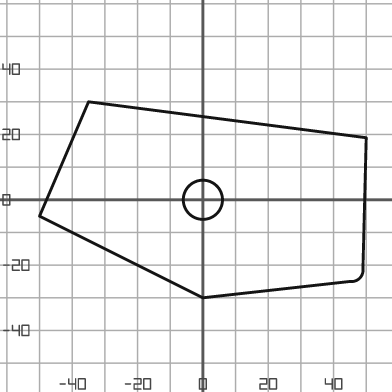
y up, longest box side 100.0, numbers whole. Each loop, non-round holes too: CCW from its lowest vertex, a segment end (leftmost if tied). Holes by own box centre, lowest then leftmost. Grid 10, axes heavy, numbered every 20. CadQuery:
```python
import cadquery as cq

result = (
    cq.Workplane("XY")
    .moveTo(0.0, -30.0)
    .lineTo(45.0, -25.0)
    .threePointArc((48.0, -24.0), (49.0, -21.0))
    .lineTo(50.0, 19.0)
    .lineTo(-35.0, 30.0)
    .lineTo(-50.0, -5.0)
    .close()
    .moveTo(0.0, 0.0)
    .circle(6.0)
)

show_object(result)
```